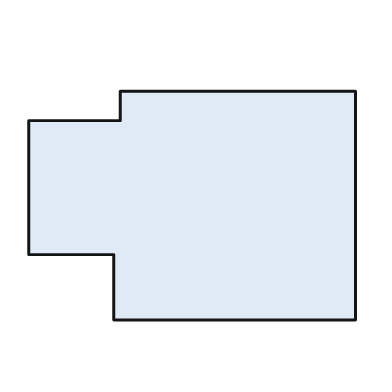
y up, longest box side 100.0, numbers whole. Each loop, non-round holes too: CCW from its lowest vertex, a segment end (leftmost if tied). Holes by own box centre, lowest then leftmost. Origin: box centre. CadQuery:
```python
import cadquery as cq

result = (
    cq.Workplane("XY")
    .moveTo(-24.0, -35.0)
    .lineTo(50.0, -35.0)
    .lineTo(50.0, 35.0)
    .lineTo(-22.0, 35.0)
    .lineTo(-22.0, 26.0)
    .lineTo(-50.0, 26.0)
    .lineTo(-50.0, -15.0)
    .lineTo(-24.0, -15.0)
    .close()
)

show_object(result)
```